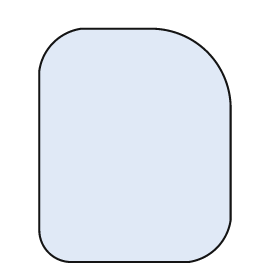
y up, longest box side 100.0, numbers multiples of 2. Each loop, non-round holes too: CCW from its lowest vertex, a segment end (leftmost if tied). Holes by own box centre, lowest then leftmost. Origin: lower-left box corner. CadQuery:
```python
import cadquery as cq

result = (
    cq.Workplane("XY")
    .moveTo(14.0, 0.0)
    .lineTo(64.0, 0.0)
    .threePointArc((76.0, 6.0), (82.0, 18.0))
    .lineTo(82.0, 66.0)
    .threePointArc((72.0, 90.0), (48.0, 100.0))
    .lineTo(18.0, 100.0)
    .threePointArc((6.0, 94.0), (0.0, 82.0))
    .lineTo(0.0, 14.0)
    .threePointArc((4.0, 4.0), (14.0, 0.0))
    .close()
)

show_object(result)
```